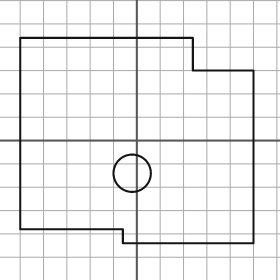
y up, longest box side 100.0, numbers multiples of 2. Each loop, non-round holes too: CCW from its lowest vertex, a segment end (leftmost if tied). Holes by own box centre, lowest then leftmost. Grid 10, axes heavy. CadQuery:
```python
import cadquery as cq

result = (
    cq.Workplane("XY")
    .moveTo(-6.0, -44.0)
    .lineTo(50.0, -44.0)
    .lineTo(50.0, 30.0)
    .lineTo(24.0, 30.0)
    .lineTo(24.0, 44.0)
    .lineTo(-50.0, 44.0)
    .lineTo(-50.0, -38.0)
    .lineTo(-6.0, -38.0)
    .close()
    .moveTo(-2.0, -14.0)
    .circle(8.0)
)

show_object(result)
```